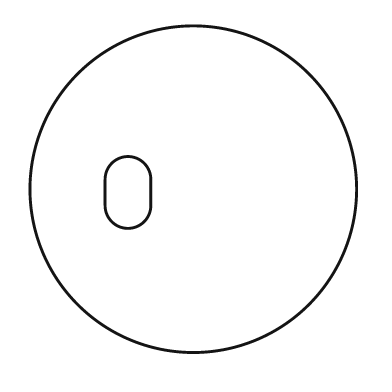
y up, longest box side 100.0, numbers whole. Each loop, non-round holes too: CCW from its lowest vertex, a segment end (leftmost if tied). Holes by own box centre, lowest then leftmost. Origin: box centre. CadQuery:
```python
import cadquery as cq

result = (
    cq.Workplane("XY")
    .moveTo(0.0, 0.0)
    .circle(50.0)
    .moveTo(-27.0, -5.0)
    .threePointArc((-20.0, -12.0), (-13.0, -5.0))
    .lineTo(-13.0, 3.0)
    .threePointArc((-20.0, 10.0), (-27.0, 3.0))
    .close()
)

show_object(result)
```